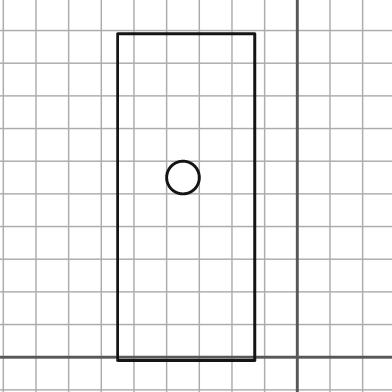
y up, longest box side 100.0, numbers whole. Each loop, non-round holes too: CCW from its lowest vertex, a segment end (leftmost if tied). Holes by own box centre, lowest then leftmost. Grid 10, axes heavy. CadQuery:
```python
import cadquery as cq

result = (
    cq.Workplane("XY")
    .moveTo(-55.0, -1.0)
    .lineTo(-13.0, -1.0)
    .lineTo(-13.0, 99.0)
    .lineTo(-55.0, 99.0)
    .close()
    .moveTo(-35.0, 55.0)
    .circle(5.0)
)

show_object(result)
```